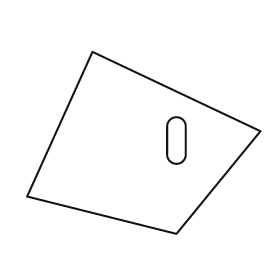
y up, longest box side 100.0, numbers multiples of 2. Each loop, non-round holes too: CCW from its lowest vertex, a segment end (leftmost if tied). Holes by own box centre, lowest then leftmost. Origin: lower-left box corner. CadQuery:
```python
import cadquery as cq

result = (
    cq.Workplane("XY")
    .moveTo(64.0, 0.0)
    .lineTo(100.0, 44.0)
    .lineTo(28.0, 78.0)
    .lineTo(0.0, 16.0)
    .close()
    .moveTo(60.0, 34.0)
    .threePointArc((64.0, 30.0), (68.0, 34.0))
    .lineTo(68.0, 46.0)
    .threePointArc((64.0, 50.0), (60.0, 46.0))
    .close()
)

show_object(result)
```